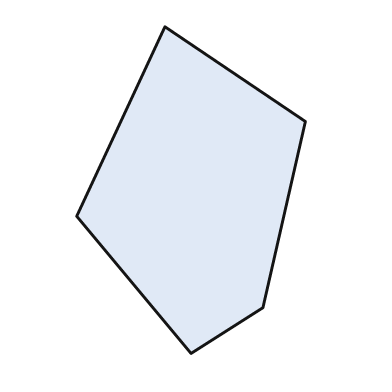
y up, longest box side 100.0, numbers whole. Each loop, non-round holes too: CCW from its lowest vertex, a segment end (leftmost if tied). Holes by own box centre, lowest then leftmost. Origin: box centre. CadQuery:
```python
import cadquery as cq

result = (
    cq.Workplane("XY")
    .moveTo(0.0, -50.0)
    .lineTo(22.0, -36.0)
    .lineTo(35.0, 21.0)
    .lineTo(-8.0, 50.0)
    .lineTo(-35.0, -8.0)
    .close()
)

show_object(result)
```